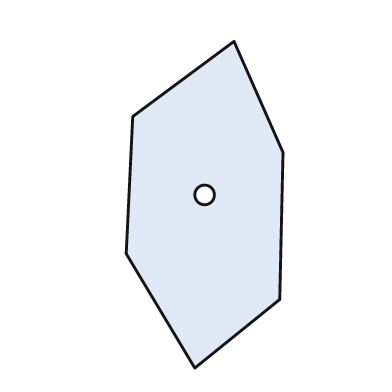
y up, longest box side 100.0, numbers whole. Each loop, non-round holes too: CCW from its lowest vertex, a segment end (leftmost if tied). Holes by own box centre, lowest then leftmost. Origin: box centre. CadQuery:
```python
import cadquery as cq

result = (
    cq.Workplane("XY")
    .moveTo(-3.0, -50.0)
    .lineTo(23.0, -29.0)
    .lineTo(24.0, 16.0)
    .lineTo(9.0, 50.0)
    .lineTo(-22.0, 27.0)
    .lineTo(-24.0, -15.0)
    .close()
    .moveTo(0.0, 3.0)
    .circle(3.0)
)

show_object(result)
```